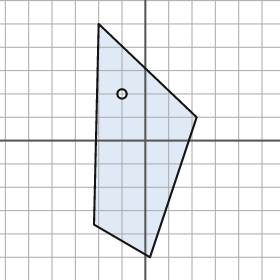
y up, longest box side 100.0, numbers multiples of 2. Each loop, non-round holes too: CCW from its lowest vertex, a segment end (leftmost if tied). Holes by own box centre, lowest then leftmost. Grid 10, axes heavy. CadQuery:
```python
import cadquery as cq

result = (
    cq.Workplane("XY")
    .moveTo(2.0, -50.0)
    .lineTo(22.0, 10.0)
    .lineTo(-20.0, 50.0)
    .lineTo(-22.0, -36.0)
    .close()
    .moveTo(-10.0, 20.0)
    .circle(2.0)
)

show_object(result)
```